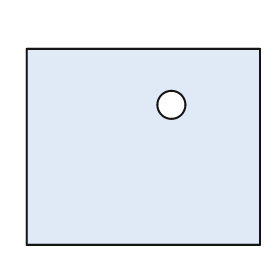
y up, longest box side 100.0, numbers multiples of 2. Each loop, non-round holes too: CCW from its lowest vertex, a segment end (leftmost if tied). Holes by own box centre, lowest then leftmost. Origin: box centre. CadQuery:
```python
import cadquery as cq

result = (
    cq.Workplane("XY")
    .moveTo(-50.0, -42.0)
    .lineTo(50.0, -42.0)
    .lineTo(50.0, 42.0)
    .lineTo(-50.0, 42.0)
    .close()
    .moveTo(12.0, 18.0)
    .circle(6.0)
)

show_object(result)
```